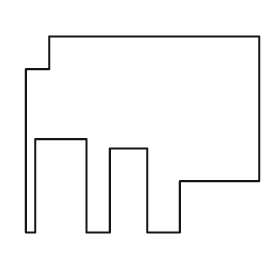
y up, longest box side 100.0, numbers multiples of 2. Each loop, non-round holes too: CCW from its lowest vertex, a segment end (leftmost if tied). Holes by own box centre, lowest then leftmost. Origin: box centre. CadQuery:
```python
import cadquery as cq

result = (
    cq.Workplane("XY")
    .moveTo(-50.0, -42.0)
    .lineTo(-46.0, -42.0)
    .lineTo(-46.0, -2.0)
    .lineTo(-24.0, -2.0)
    .lineTo(-24.0, -42.0)
    .lineTo(-14.0, -42.0)
    .lineTo(-14.0, -6.0)
    .lineTo(2.0, -6.0)
    .lineTo(2.0, -42.0)
    .lineTo(16.0, -42.0)
    .lineTo(16.0, -20.0)
    .lineTo(50.0, -20.0)
    .lineTo(50.0, 42.0)
    .lineTo(-40.0, 42.0)
    .lineTo(-40.0, 28.0)
    .lineTo(-50.0, 28.0)
    .close()
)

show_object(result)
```